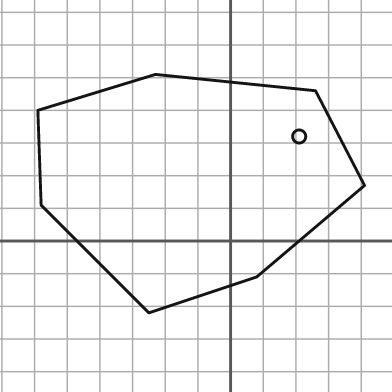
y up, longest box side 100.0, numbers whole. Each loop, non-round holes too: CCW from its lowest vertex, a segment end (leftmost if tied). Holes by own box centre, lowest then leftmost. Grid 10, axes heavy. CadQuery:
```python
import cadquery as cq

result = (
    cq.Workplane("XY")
    .moveTo(-25.0, -22.0)
    .lineTo(8.0, -11.0)
    .lineTo(41.0, 17.0)
    .lineTo(26.0, 46.0)
    .lineTo(-23.0, 51.0)
    .lineTo(-59.0, 40.0)
    .lineTo(-58.0, 11.0)
    .close()
    .moveTo(21.0, 32.0)
    .circle(2.0)
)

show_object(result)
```